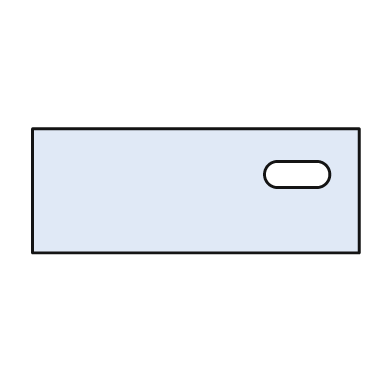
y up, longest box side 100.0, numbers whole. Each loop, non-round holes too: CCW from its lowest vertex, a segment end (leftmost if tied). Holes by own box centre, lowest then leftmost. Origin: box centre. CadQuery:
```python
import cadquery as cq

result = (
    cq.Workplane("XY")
    .moveTo(-50.0, -19.0)
    .lineTo(50.0, -19.0)
    .lineTo(50.0, 19.0)
    .lineTo(-50.0, 19.0)
    .close()
    .moveTo(25.0, 1.0)
    .lineTo(37.0, 1.0)
    .threePointArc((41.0, 5.0), (37.0, 9.0))
    .lineTo(25.0, 9.0)
    .threePointArc((21.0, 5.0), (25.0, 1.0))
    .close()
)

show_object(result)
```